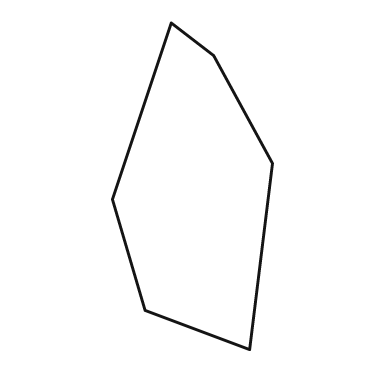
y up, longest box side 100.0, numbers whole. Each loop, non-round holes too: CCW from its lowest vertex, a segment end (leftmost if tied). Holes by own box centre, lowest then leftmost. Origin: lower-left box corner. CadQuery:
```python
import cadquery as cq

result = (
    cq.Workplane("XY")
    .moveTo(42.0, 0.0)
    .lineTo(49.0, 57.0)
    .lineTo(31.0, 90.0)
    .lineTo(18.0, 100.0)
    .lineTo(0.0, 46.0)
    .lineTo(10.0, 12.0)
    .close()
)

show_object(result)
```